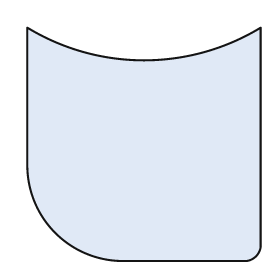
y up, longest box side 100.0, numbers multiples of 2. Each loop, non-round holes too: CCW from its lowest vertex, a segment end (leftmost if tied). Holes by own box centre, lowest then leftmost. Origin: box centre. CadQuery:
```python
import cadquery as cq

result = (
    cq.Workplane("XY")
    .moveTo(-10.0, -50.0)
    .lineTo(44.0, -50.0)
    .threePointArc((48.0, -48.0), (50.0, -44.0))
    .lineTo(50.0, 50.0)
    .threePointArc((0.0, 36.0), (-50.0, 50.0))
    .lineTo(-50.0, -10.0)
    .threePointArc((-38.0, -38.0), (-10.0, -50.0))
    .close()
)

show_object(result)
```